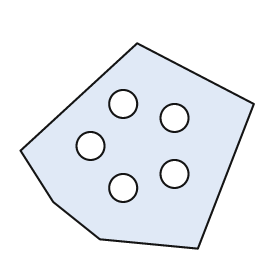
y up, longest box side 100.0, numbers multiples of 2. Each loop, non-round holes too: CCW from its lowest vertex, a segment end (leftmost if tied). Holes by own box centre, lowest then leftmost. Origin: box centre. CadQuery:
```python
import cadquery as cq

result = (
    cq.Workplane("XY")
    .moveTo(26.0, -44.0)
    .lineTo(50.0, 18.0)
    .lineTo(0.0, 44.0)
    .lineTo(-50.0, -2.0)
    .lineTo(-36.0, -24.0)
    .lineTo(-16.0, -40.0)
    .close()
    .moveTo(-6.0, -18.0)
    .circle(6.0)
    .moveTo(16.0, -12.0)
    .circle(6.0)
    .moveTo(-20.0, 0.0)
    .circle(6.0)
    .moveTo(16.0, 12.0)
    .circle(6.0)
    .moveTo(-6.0, 18.0)
    .circle(6.0)
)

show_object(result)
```